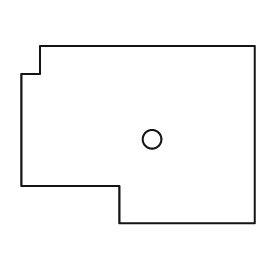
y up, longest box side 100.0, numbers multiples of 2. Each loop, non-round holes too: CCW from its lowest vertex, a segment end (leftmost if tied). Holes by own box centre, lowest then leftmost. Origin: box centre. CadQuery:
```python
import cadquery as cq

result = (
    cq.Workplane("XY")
    .moveTo(-8.0, -38.0)
    .lineTo(50.0, -38.0)
    .lineTo(50.0, 38.0)
    .lineTo(-42.0, 38.0)
    .lineTo(-42.0, 26.0)
    .lineTo(-50.0, 26.0)
    .lineTo(-50.0, -22.0)
    .lineTo(-8.0, -22.0)
    .close()
    .moveTo(6.0, -2.0)
    .circle(4.0)
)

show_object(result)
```